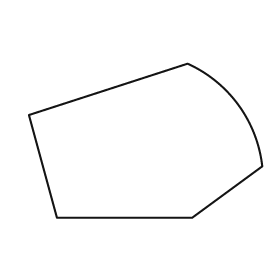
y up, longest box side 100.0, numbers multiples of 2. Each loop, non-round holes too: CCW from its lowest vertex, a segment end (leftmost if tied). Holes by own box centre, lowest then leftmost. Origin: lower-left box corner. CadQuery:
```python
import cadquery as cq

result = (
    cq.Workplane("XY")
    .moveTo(12.0, 0.0)
    .lineTo(70.0, 0.0)
    .lineTo(100.0, 22.0)
    .threePointArc((90.0, 48.0), (68.0, 66.0))
    .lineTo(0.0, 44.0)
    .close()
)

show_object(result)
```